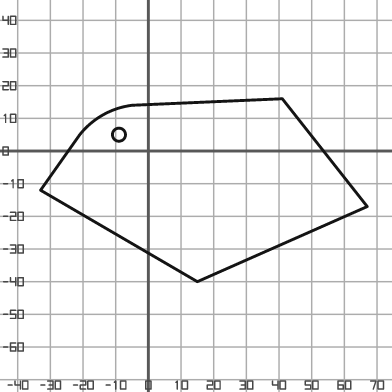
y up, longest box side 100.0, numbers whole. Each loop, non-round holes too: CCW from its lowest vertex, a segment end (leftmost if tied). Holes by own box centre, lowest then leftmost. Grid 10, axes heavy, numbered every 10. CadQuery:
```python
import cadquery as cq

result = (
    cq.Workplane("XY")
    .moveTo(15.0, -40.0)
    .lineTo(67.0, -17.0)
    .lineTo(41.0, 16.0)
    .lineTo(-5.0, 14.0)
    .threePointArc((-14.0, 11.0), (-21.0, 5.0))
    .lineTo(-33.0, -12.0)
    .close()
    .moveTo(-9.0, 5.0)
    .circle(2.0)
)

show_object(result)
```